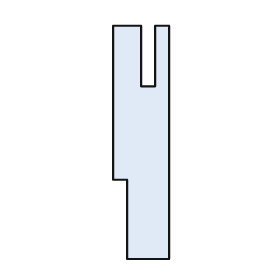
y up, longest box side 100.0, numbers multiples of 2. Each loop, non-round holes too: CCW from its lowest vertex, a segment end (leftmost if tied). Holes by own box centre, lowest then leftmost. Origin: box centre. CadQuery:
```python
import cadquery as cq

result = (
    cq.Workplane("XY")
    .moveTo(-6.0, -50.0)
    .lineTo(12.0, -50.0)
    .lineTo(12.0, 50.0)
    .lineTo(6.0, 50.0)
    .lineTo(6.0, 24.0)
    .lineTo(0.0, 24.0)
    .lineTo(0.0, 50.0)
    .lineTo(-12.0, 50.0)
    .lineTo(-12.0, -16.0)
    .lineTo(-6.0, -16.0)
    .close()
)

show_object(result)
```